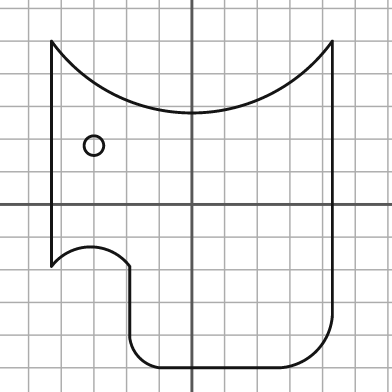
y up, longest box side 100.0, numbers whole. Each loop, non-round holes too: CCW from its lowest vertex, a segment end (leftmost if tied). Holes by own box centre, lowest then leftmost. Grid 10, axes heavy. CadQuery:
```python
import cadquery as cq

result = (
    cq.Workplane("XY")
    .moveTo(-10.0, -50.0)
    .lineTo(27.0, -50.0)
    .threePointArc((38.0, -45.0), (43.0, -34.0))
    .lineTo(43.0, 50.0)
    .threePointArc((0.0, 28.0), (-43.0, 50.0))
    .lineTo(-43.0, -19.0)
    .threePointArc((-31.0, -13.0), (-19.0, -19.0))
    .lineTo(-19.0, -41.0)
    .threePointArc((-16.0, -47.0), (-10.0, -50.0))
    .close()
    .moveTo(-30.0, 18.0)
    .circle(3.0)
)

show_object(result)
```